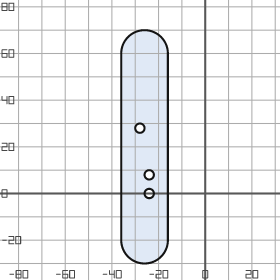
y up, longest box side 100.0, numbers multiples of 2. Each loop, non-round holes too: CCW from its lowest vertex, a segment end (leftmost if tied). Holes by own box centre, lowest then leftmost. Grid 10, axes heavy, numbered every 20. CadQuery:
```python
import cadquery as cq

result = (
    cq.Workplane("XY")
    .moveTo(-36.0, -20.0)
    .threePointArc((-26.0, -30.0), (-16.0, -20.0))
    .lineTo(-16.0, 60.0)
    .threePointArc((-26.0, 70.0), (-36.0, 60.0))
    .close()
    .moveTo(-24.0, 0.0)
    .circle(2.0)
    .moveTo(-24.0, 8.0)
    .circle(2.0)
    .moveTo(-28.0, 28.0)
    .circle(2.0)
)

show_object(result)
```